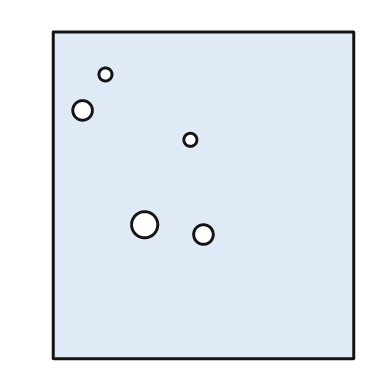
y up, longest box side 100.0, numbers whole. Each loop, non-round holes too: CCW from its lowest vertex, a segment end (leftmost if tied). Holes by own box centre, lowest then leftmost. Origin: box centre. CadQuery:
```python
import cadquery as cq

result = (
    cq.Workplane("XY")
    .moveTo(-46.0, -50.0)
    .lineTo(46.0, -50.0)
    .lineTo(46.0, 50.0)
    .lineTo(-46.0, 50.0)
    .close()
    .moveTo(0.0, -12.0)
    .circle(3.0)
    .moveTo(-18.0, -9.0)
    .circle(4.0)
    .moveTo(-4.0, 17.0)
    .circle(2.0)
    .moveTo(-37.0, 26.0)
    .circle(3.0)
    .moveTo(-30.0, 37.0)
    .circle(2.0)
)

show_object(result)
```